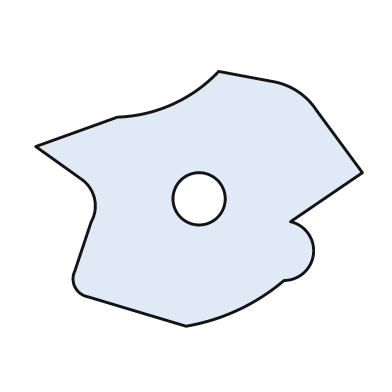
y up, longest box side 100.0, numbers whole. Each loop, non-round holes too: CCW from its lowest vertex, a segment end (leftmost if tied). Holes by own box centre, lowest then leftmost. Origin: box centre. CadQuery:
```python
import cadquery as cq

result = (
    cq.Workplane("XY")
    .moveTo(-4.0, -39.0)
    .threePointArc((12.0, -34.0), (26.0, -25.0))
    .threePointArc((35.0, -17.0), (28.0, -7.0))
    .lineTo(50.0, 8.0)
    .lineTo(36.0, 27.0)
    .threePointArc((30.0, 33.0), (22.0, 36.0))
    .lineTo(6.0, 39.0)
    .threePointArc((-8.0, 29.0), (-25.0, 25.0))
    .lineTo(-50.0, 16.0)
    .lineTo(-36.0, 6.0)
    .threePointArc((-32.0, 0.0), (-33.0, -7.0))
    .lineTo(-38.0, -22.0)
    .threePointArc((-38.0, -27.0), (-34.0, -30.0))
    .close()
    .moveTo(0.0, 0.0)
    .circle(8.0)
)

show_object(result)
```